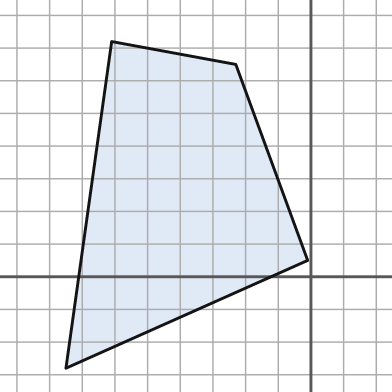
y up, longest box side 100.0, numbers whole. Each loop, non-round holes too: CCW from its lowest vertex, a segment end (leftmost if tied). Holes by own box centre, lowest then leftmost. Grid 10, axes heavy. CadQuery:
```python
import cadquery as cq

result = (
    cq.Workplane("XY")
    .moveTo(-75.0, -28.0)
    .lineTo(-1.0, 5.0)
    .lineTo(-23.0, 65.0)
    .lineTo(-61.0, 72.0)
    .close()
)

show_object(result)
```